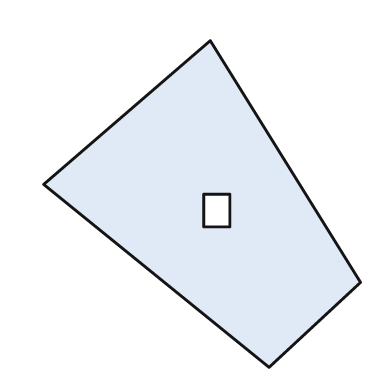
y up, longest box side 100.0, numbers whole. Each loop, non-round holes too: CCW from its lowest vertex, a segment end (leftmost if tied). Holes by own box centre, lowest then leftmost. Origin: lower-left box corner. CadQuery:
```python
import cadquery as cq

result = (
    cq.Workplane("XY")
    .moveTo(69.0, 0.0)
    .lineTo(97.0, 26.0)
    .lineTo(51.0, 100.0)
    .lineTo(0.0, 56.0)
    .close()
    .moveTo(49.0, 43.0)
    .lineTo(57.0, 43.0)
    .lineTo(57.0, 53.0)
    .lineTo(49.0, 53.0)
    .close()
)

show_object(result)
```